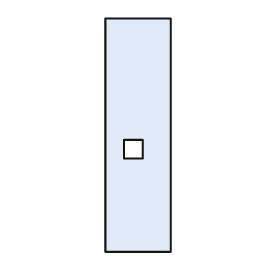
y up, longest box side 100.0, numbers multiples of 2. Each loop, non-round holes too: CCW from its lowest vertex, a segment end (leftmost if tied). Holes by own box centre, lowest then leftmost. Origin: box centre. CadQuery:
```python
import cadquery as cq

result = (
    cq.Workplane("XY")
    .moveTo(-14.0, -50.0)
    .lineTo(14.0, -50.0)
    .lineTo(14.0, 50.0)
    .lineTo(-14.0, 50.0)
    .close()
    .moveTo(-6.0, -10.0)
    .lineTo(2.0, -10.0)
    .lineTo(2.0, -2.0)
    .lineTo(-6.0, -2.0)
    .close()
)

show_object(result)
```